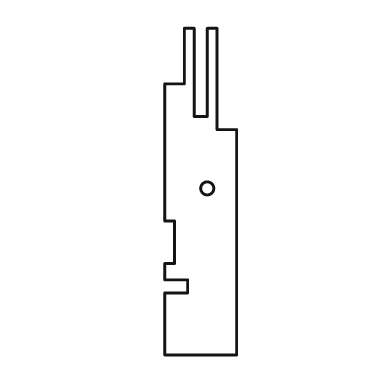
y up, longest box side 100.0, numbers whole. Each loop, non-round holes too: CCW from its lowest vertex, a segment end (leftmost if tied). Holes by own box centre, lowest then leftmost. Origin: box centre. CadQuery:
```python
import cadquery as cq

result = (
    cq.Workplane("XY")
    .moveTo(-11.0, -50.0)
    .lineTo(11.0, -50.0)
    .lineTo(11.0, 19.0)
    .lineTo(5.0, 19.0)
    .lineTo(5.0, 50.0)
    .lineTo(2.0, 50.0)
    .lineTo(2.0, 23.0)
    .lineTo(-2.0, 23.0)
    .lineTo(-2.0, 50.0)
    .lineTo(-5.0, 50.0)
    .lineTo(-5.0, 33.0)
    .lineTo(-11.0, 33.0)
    .lineTo(-11.0, -9.0)
    .lineTo(-8.0, -9.0)
    .lineTo(-8.0, -22.0)
    .lineTo(-11.0, -22.0)
    .lineTo(-11.0, -27.0)
    .lineTo(-4.0, -27.0)
    .lineTo(-4.0, -31.0)
    .lineTo(-11.0, -31.0)
    .close()
    .moveTo(2.0, 1.0)
    .circle(2.0)
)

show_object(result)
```